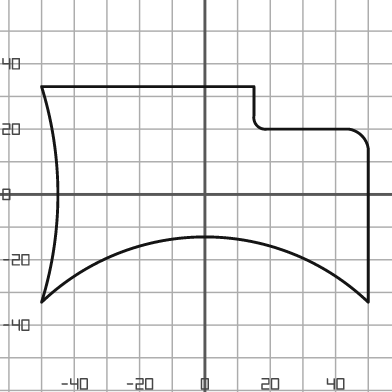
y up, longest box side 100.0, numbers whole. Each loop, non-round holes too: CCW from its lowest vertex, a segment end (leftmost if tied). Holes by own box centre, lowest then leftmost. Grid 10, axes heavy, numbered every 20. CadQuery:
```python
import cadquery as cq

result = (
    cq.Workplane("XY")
    .moveTo(-50.0, -33.0)
    .threePointArc((0.0, -13.0), (50.0, -33.0))
    .lineTo(50.0, 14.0)
    .threePointArc((48.0, 18.0), (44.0, 20.0))
    .lineTo(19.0, 20.0)
    .threePointArc((16.0, 21.0), (15.0, 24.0))
    .lineTo(15.0, 33.0)
    .lineTo(-50.0, 33.0)
    .threePointArc((-45.0, 0.0), (-50.0, -33.0))
    .close()
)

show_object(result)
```